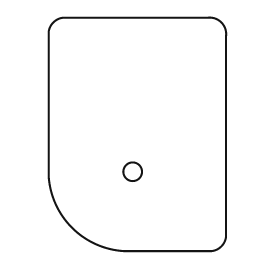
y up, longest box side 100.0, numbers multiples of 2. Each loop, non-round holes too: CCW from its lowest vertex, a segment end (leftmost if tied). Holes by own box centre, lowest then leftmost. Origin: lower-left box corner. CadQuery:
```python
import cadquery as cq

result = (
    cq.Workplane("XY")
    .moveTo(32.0, 0.0)
    .lineTo(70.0, 0.0)
    .threePointArc((74.0, 2.0), (76.0, 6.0))
    .lineTo(76.0, 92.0)
    .threePointArc((74.0, 98.0), (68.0, 100.0))
    .lineTo(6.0, 100.0)
    .threePointArc((2.0, 98.0), (0.0, 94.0))
    .lineTo(0.0, 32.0)
    .threePointArc((10.0, 10.0), (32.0, 0.0))
    .close()
    .moveTo(36.0, 34.0)
    .circle(4.0)
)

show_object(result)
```